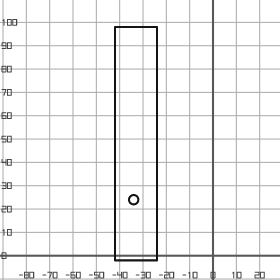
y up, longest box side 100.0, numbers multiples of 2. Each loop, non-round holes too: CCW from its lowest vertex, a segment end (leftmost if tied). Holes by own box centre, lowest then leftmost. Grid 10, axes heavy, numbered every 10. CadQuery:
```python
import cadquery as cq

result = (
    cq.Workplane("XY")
    .moveTo(-42.0, -2.0)
    .lineTo(-24.0, -2.0)
    .lineTo(-24.0, 98.0)
    .lineTo(-42.0, 98.0)
    .close()
    .moveTo(-34.0, 24.0)
    .circle(2.0)
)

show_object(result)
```